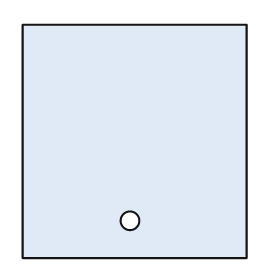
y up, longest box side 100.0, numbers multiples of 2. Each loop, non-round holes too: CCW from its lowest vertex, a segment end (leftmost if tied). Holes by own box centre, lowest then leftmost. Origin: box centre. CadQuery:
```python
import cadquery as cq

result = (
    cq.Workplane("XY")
    .moveTo(-48.0, -50.0)
    .lineTo(48.0, -50.0)
    .lineTo(48.0, 50.0)
    .lineTo(-48.0, 50.0)
    .close()
    .moveTo(-2.0, -34.0)
    .circle(4.0)
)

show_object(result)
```